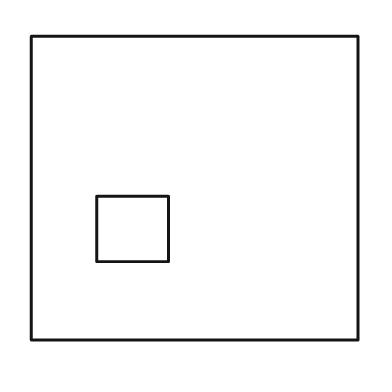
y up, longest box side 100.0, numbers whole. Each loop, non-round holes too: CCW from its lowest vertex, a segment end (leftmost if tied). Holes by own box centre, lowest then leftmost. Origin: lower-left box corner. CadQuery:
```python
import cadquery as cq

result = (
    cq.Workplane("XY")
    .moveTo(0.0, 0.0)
    .lineTo(100.0, 0.0)
    .lineTo(100.0, 93.0)
    .lineTo(0.0, 93.0)
    .close()
    .moveTo(20.0, 24.0)
    .lineTo(42.0, 24.0)
    .lineTo(42.0, 44.0)
    .lineTo(20.0, 44.0)
    .close()
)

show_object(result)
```